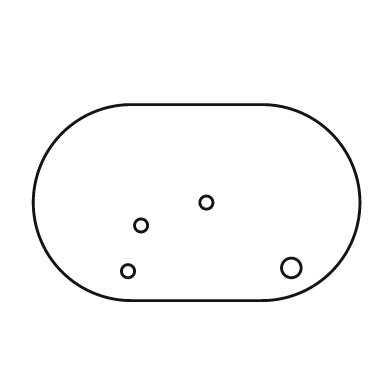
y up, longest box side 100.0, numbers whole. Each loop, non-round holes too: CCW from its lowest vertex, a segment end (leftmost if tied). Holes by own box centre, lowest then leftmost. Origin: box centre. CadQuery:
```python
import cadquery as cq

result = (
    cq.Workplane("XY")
    .moveTo(-20.0, -30.0)
    .lineTo(20.0, -30.0)
    .threePointArc((50.0, 0.0), (20.0, 30.0))
    .lineTo(-20.0, 30.0)
    .threePointArc((-50.0, 0.0), (-20.0, -30.0))
    .close()
    .moveTo(-21.0, -21.0)
    .circle(2.0)
    .moveTo(29.0, -20.0)
    .circle(3.0)
    .moveTo(-17.0, -7.0)
    .circle(2.0)
    .moveTo(3.0, 0.0)
    .circle(2.0)
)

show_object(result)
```